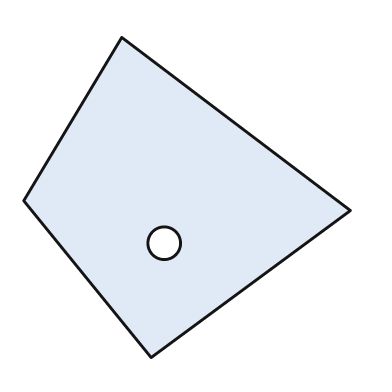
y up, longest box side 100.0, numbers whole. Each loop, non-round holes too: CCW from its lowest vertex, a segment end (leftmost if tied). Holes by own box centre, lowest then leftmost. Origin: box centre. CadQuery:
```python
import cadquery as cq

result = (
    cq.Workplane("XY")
    .moveTo(-11.0, -49.0)
    .lineTo(50.0, -4.0)
    .lineTo(-20.0, 49.0)
    .lineTo(-50.0, -1.0)
    .close()
    .moveTo(-7.0, -14.0)
    .circle(5.0)
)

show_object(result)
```